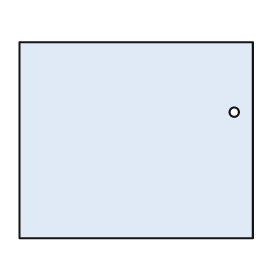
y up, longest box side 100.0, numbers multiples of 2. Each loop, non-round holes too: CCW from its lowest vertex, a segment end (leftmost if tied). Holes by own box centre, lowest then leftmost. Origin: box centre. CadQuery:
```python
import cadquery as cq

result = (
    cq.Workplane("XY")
    .moveTo(-50.0, -42.0)
    .lineTo(50.0, -42.0)
    .lineTo(50.0, 42.0)
    .lineTo(-50.0, 42.0)
    .close()
    .moveTo(42.0, 12.0)
    .circle(2.0)
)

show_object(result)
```